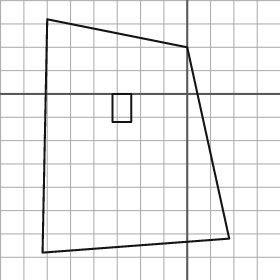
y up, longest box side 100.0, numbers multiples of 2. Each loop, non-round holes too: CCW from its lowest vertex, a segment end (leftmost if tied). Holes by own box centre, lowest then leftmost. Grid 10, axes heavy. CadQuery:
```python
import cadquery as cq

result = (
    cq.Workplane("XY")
    .moveTo(-62.0, -68.0)
    .lineTo(18.0, -62.0)
    .lineTo(0.0, 20.0)
    .lineTo(-60.0, 32.0)
    .close()
    .moveTo(-32.0, -12.0)
    .lineTo(-24.0, -12.0)
    .lineTo(-24.0, 0.0)
    .lineTo(-32.0, 0.0)
    .close()
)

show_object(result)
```